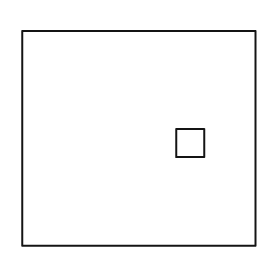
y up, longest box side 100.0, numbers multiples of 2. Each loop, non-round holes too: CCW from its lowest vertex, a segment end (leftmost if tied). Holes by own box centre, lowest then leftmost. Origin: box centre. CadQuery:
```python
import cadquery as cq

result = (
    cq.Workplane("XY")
    .moveTo(-50.0, -46.0)
    .lineTo(50.0, -46.0)
    .lineTo(50.0, 46.0)
    .lineTo(-50.0, 46.0)
    .close()
    .moveTo(16.0, -8.0)
    .lineTo(28.0, -8.0)
    .lineTo(28.0, 4.0)
    .lineTo(16.0, 4.0)
    .close()
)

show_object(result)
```